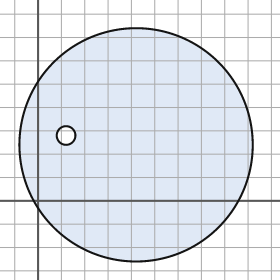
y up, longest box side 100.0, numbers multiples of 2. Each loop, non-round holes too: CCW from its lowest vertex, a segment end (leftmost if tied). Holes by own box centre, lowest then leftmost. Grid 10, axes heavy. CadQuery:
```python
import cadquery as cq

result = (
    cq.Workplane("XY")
    .moveTo(42.0, 24.0)
    .circle(50.0)
    .moveTo(12.0, 28.0)
    .circle(4.0)
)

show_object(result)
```